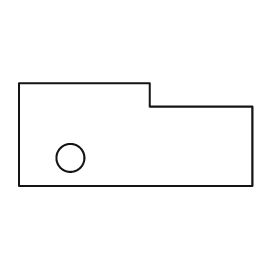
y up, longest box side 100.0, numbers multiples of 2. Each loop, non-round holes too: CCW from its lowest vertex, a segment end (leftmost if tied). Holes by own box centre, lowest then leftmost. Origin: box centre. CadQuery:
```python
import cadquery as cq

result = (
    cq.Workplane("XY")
    .moveTo(-50.0, -22.0)
    .lineTo(50.0, -22.0)
    .lineTo(50.0, 12.0)
    .lineTo(6.0, 12.0)
    .lineTo(6.0, 22.0)
    .lineTo(-50.0, 22.0)
    .close()
    .moveTo(-28.0, -10.0)
    .circle(6.0)
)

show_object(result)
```